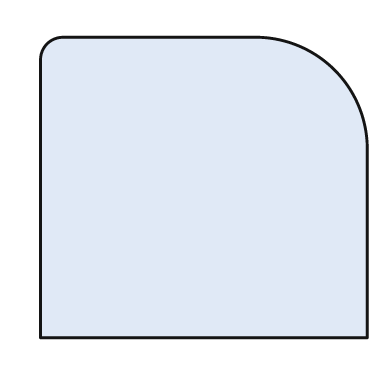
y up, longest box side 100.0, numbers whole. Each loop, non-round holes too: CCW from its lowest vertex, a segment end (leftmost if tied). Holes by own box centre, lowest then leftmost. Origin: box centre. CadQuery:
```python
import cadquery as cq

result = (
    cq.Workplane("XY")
    .moveTo(-50.0, -46.0)
    .lineTo(50.0, -46.0)
    .lineTo(50.0, 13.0)
    .threePointArc((40.0, 36.0), (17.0, 46.0))
    .lineTo(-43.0, 46.0)
    .threePointArc((-48.0, 44.0), (-50.0, 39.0))
    .close()
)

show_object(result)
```